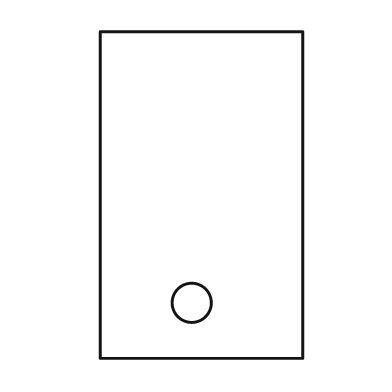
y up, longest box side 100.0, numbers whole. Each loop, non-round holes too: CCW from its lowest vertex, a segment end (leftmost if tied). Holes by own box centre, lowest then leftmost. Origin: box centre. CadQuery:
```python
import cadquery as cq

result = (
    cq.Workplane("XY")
    .moveTo(-31.0, -50.0)
    .lineTo(31.0, -50.0)
    .lineTo(31.0, 50.0)
    .lineTo(-31.0, 50.0)
    .close()
    .moveTo(-3.0, -33.0)
    .circle(6.0)
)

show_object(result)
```